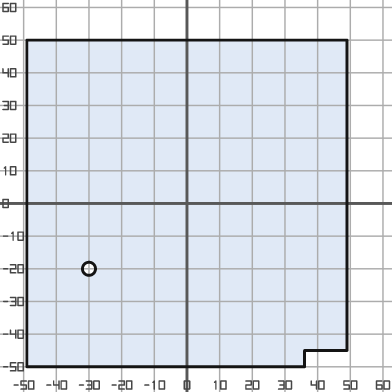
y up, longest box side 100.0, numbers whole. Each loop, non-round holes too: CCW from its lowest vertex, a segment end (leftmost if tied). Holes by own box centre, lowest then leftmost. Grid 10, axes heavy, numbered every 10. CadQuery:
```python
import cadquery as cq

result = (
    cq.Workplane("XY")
    .moveTo(-49.0, -50.0)
    .lineTo(36.0, -50.0)
    .lineTo(36.0, -45.0)
    .lineTo(49.0, -45.0)
    .lineTo(49.0, 50.0)
    .lineTo(-49.0, 50.0)
    .close()
    .moveTo(-30.0, -20.0)
    .circle(2.0)
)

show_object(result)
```